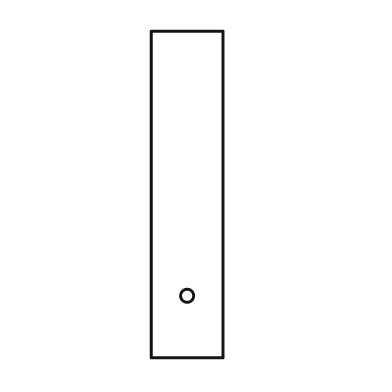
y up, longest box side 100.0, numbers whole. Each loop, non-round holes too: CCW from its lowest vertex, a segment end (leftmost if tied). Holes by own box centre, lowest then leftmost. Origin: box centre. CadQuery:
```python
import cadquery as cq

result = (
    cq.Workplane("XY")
    .moveTo(-11.0, -50.0)
    .lineTo(11.0, -50.0)
    .lineTo(11.0, 50.0)
    .lineTo(-11.0, 50.0)
    .close()
    .moveTo(0.0, -31.0)
    .circle(2.0)
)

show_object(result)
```